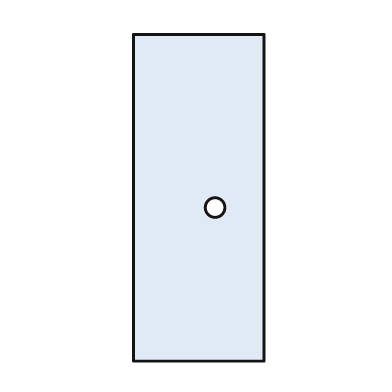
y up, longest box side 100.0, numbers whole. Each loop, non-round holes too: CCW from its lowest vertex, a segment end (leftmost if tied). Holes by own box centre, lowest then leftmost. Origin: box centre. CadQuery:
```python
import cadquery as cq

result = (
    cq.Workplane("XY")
    .moveTo(-20.0, -50.0)
    .lineTo(20.0, -50.0)
    .lineTo(20.0, 50.0)
    .lineTo(-20.0, 50.0)
    .close()
    .moveTo(5.0, -3.0)
    .circle(3.0)
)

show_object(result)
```